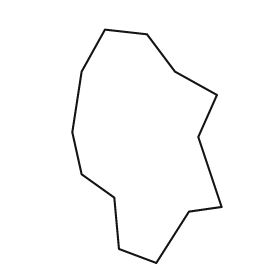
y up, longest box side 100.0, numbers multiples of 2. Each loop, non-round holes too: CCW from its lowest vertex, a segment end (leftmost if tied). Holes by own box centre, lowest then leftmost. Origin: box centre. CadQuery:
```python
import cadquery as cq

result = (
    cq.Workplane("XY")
    .moveTo(4.0, -50.0)
    .lineTo(18.0, -28.0)
    .lineTo(32.0, -26.0)
    .lineTo(22.0, 4.0)
    .lineTo(30.0, 22.0)
    .lineTo(12.0, 32.0)
    .lineTo(0.0, 48.0)
    .lineTo(-18.0, 50.0)
    .lineTo(-28.0, 32.0)
    .lineTo(-32.0, 6.0)
    .lineTo(-28.0, -12.0)
    .lineTo(-14.0, -22.0)
    .lineTo(-12.0, -44.0)
    .close()
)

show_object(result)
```